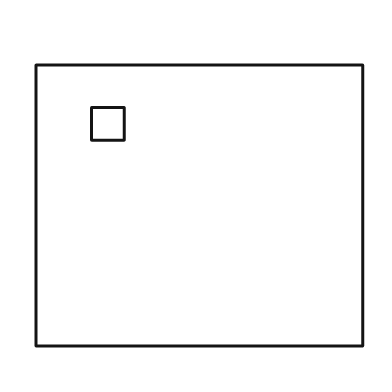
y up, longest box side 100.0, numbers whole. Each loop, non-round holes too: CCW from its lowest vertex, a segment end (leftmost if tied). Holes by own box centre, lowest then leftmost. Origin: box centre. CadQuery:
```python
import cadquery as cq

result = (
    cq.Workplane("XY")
    .moveTo(-50.0, -43.0)
    .lineTo(50.0, -43.0)
    .lineTo(50.0, 43.0)
    .lineTo(-50.0, 43.0)
    .close()
    .moveTo(-33.0, 20.0)
    .lineTo(-23.0, 20.0)
    .lineTo(-23.0, 30.0)
    .lineTo(-33.0, 30.0)
    .close()
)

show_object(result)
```